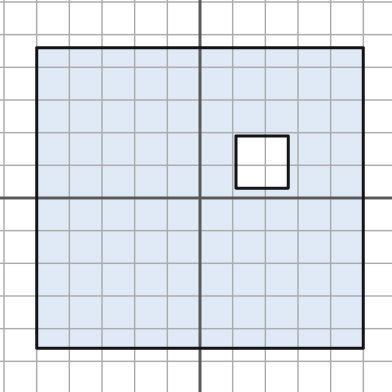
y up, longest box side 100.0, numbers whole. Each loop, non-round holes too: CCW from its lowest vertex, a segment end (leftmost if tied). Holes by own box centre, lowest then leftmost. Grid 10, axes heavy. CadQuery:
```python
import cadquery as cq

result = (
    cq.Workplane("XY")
    .moveTo(-50.0, -46.0)
    .lineTo(50.0, -46.0)
    .lineTo(50.0, 46.0)
    .lineTo(-50.0, 46.0)
    .close()
    .moveTo(11.0, 3.0)
    .lineTo(27.0, 3.0)
    .lineTo(27.0, 19.0)
    .lineTo(11.0, 19.0)
    .close()
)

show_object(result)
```